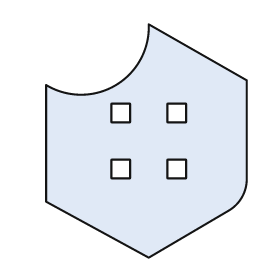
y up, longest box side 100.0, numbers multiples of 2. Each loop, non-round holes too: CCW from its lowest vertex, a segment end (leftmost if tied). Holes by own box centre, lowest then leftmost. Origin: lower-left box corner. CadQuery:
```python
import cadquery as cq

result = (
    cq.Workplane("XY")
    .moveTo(44.0, 0.0)
    .lineTo(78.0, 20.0)
    .threePointArc((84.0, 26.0), (86.0, 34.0))
    .lineTo(86.0, 76.0)
    .lineTo(44.0, 100.0)
    .threePointArc((30.0, 74.0), (0.0, 74.0))
    .lineTo(0.0, 24.0)
    .close()
    .moveTo(28.0, 34.0)
    .lineTo(36.0, 34.0)
    .lineTo(36.0, 42.0)
    .lineTo(28.0, 42.0)
    .close()
    .moveTo(52.0, 34.0)
    .lineTo(60.0, 34.0)
    .lineTo(60.0, 42.0)
    .lineTo(52.0, 42.0)
    .close()
    .moveTo(28.0, 58.0)
    .lineTo(36.0, 58.0)
    .lineTo(36.0, 66.0)
    .lineTo(28.0, 66.0)
    .close()
    .moveTo(52.0, 58.0)
    .lineTo(60.0, 58.0)
    .lineTo(60.0, 66.0)
    .lineTo(52.0, 66.0)
    .close()
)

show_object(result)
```